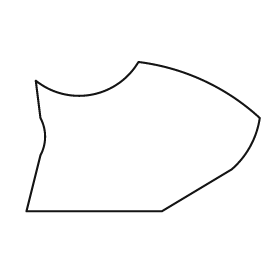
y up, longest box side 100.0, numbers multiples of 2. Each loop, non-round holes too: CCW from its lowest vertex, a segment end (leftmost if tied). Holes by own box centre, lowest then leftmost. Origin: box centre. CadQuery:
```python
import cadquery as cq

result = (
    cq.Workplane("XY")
    .moveTo(-50.0, -32.0)
    .lineTo(8.0, -32.0)
    .lineTo(38.0, -14.0)
    .threePointArc((46.0, -4.0), (50.0, 8.0))
    .threePointArc((26.0, 24.0), (-2.0, 32.0))
    .threePointArc((-22.0, 18.0), (-46.0, 24.0))
    .lineTo(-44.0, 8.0)
    .threePointArc((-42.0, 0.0), (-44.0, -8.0))
    .close()
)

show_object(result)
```